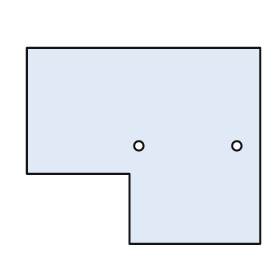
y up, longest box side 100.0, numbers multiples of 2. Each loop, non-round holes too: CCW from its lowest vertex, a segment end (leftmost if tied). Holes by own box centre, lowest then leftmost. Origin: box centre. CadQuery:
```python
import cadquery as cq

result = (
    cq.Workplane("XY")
    .moveTo(-6.0, -42.0)
    .lineTo(50.0, -42.0)
    .lineTo(50.0, 42.0)
    .lineTo(-50.0, 42.0)
    .lineTo(-50.0, -12.0)
    .lineTo(-6.0, -12.0)
    .close()
    .moveTo(-2.0, 0.0)
    .circle(2.0)
    .moveTo(40.0, 0.0)
    .circle(2.0)
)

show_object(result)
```